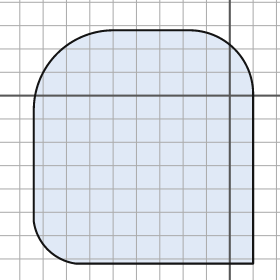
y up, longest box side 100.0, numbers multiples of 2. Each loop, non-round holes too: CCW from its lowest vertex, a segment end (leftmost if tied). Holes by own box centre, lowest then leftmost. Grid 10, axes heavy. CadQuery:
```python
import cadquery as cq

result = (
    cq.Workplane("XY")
    .moveTo(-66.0, -72.0)
    .lineTo(10.0, -72.0)
    .lineTo(10.0, 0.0)
    .threePointArc((2.0, 20.0), (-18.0, 28.0))
    .lineTo(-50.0, 28.0)
    .threePointArc((-74.0, 18.0), (-84.0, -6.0))
    .lineTo(-84.0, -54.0)
    .threePointArc((-78.0, -66.0), (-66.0, -72.0))
    .close()
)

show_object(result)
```